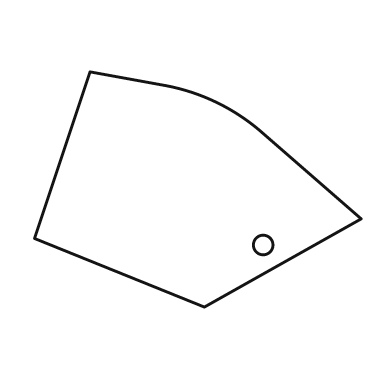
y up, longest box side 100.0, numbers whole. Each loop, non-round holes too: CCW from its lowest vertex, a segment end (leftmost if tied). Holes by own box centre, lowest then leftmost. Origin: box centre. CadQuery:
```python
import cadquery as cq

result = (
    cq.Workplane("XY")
    .moveTo(2.0, -36.0)
    .lineTo(50.0, -9.0)
    .lineTo(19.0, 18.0)
    .threePointArc((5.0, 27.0), (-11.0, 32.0))
    .lineTo(-33.0, 36.0)
    .lineTo(-50.0, -15.0)
    .close()
    .moveTo(20.0, -17.0)
    .circle(3.0)
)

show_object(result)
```